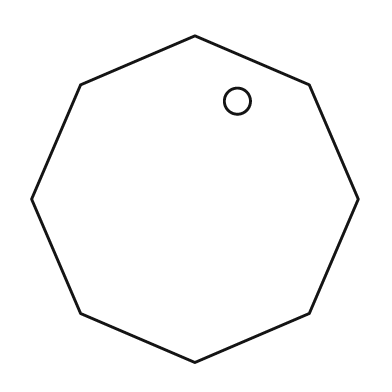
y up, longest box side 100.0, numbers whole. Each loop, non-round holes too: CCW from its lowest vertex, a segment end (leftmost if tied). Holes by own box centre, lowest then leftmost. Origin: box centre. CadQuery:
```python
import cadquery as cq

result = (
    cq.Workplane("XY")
    .moveTo(0.0, -50.0)
    .lineTo(35.0, -35.0)
    .lineTo(50.0, 0.0)
    .lineTo(35.0, 35.0)
    .lineTo(0.0, 50.0)
    .lineTo(-35.0, 35.0)
    .lineTo(-50.0, 0.0)
    .lineTo(-35.0, -35.0)
    .close()
    .moveTo(13.0, 30.0)
    .circle(4.0)
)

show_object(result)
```